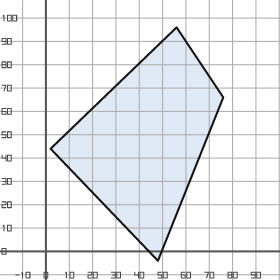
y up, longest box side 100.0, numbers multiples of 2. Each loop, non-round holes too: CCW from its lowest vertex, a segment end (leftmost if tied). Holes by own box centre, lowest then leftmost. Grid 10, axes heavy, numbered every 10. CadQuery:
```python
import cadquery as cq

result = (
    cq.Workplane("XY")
    .moveTo(48.0, -4.0)
    .lineTo(76.0, 66.0)
    .lineTo(56.0, 96.0)
    .lineTo(2.0, 44.0)
    .close()
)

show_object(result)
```